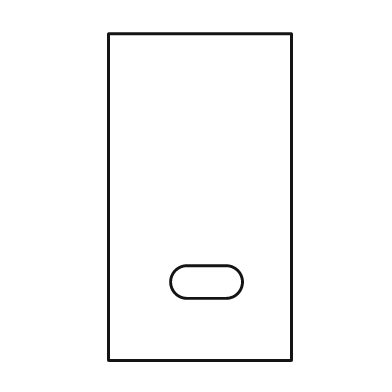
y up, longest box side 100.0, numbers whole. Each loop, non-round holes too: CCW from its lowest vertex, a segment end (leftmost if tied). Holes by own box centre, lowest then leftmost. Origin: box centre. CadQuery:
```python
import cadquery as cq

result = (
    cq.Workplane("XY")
    .moveTo(-28.0, -50.0)
    .lineTo(28.0, -50.0)
    .lineTo(28.0, 50.0)
    .lineTo(-28.0, 50.0)
    .close()
    .moveTo(-4.0, -31.0)
    .lineTo(8.0, -31.0)
    .threePointArc((13.0, -26.0), (8.0, -21.0))
    .lineTo(-4.0, -21.0)
    .threePointArc((-9.0, -26.0), (-4.0, -31.0))
    .close()
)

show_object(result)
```